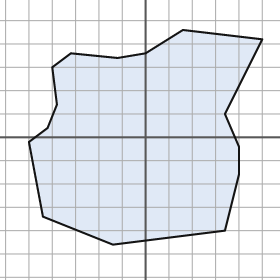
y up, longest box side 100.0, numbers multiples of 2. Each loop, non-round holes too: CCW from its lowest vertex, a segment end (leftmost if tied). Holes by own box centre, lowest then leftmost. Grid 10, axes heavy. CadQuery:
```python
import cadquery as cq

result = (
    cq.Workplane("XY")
    .moveTo(-14.0, -46.0)
    .lineTo(34.0, -40.0)
    .lineTo(40.0, -16.0)
    .lineTo(40.0, -4.0)
    .lineTo(34.0, 10.0)
    .lineTo(50.0, 42.0)
    .lineTo(16.0, 46.0)
    .lineTo(0.0, 36.0)
    .lineTo(-12.0, 34.0)
    .lineTo(-32.0, 36.0)
    .lineTo(-40.0, 30.0)
    .lineTo(-38.0, 14.0)
    .lineTo(-42.0, 4.0)
    .lineTo(-50.0, -2.0)
    .lineTo(-44.0, -34.0)
    .close()
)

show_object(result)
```